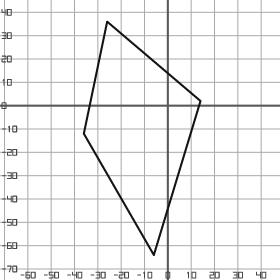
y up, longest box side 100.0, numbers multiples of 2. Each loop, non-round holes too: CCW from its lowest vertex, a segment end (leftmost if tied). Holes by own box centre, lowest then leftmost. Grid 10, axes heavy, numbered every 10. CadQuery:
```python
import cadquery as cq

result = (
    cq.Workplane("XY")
    .moveTo(-6.0, -64.0)
    .lineTo(14.0, 2.0)
    .lineTo(-26.0, 36.0)
    .lineTo(-36.0, -12.0)
    .close()
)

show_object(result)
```